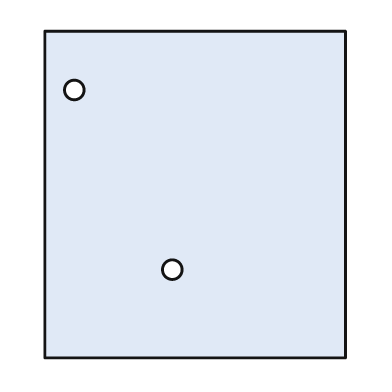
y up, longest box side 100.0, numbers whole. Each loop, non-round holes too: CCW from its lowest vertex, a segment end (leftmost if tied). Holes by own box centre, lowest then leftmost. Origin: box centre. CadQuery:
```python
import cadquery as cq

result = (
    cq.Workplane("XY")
    .moveTo(-46.0, -50.0)
    .lineTo(46.0, -50.0)
    .lineTo(46.0, 50.0)
    .lineTo(-46.0, 50.0)
    .close()
    .moveTo(-7.0, -23.0)
    .circle(3.0)
    .moveTo(-37.0, 32.0)
    .circle(3.0)
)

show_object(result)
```